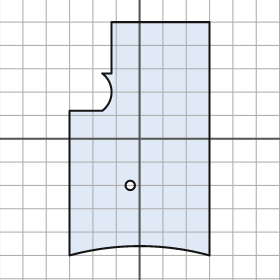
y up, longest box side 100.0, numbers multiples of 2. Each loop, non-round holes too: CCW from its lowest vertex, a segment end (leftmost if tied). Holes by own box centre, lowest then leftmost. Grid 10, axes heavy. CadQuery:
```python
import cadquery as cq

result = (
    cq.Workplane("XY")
    .moveTo(-30.0, -50.0)
    .threePointArc((0.0, -46.0), (30.0, -50.0))
    .lineTo(30.0, 50.0)
    .lineTo(-12.0, 50.0)
    .lineTo(-12.0, 28.0)
    .lineTo(-16.0, 28.0)
    .threePointArc((-12.0, 20.0), (-16.0, 12.0))
    .lineTo(-30.0, 12.0)
    .close()
    .moveTo(-4.0, -20.0)
    .circle(2.0)
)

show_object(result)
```